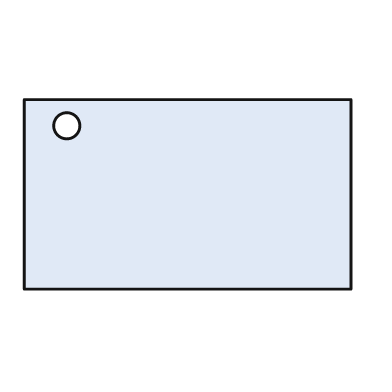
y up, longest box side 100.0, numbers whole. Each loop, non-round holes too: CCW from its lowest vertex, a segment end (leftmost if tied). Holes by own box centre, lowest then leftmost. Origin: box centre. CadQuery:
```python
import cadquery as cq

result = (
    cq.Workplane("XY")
    .moveTo(-50.0, -29.0)
    .lineTo(50.0, -29.0)
    .lineTo(50.0, 29.0)
    .lineTo(-50.0, 29.0)
    .close()
    .moveTo(-37.0, 21.0)
    .circle(4.0)
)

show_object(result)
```